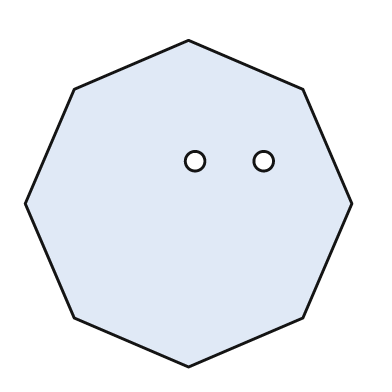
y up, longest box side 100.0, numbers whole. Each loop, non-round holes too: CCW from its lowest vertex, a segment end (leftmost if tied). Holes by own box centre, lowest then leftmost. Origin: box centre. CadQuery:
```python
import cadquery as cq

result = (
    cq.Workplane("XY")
    .moveTo(0.0, -50.0)
    .lineTo(35.0, -35.0)
    .lineTo(50.0, 0.0)
    .lineTo(35.0, 35.0)
    .lineTo(0.0, 50.0)
    .lineTo(-35.0, 35.0)
    .lineTo(-50.0, 0.0)
    .lineTo(-35.0, -35.0)
    .close()
    .moveTo(2.0, 13.0)
    .circle(3.0)
    .moveTo(23.0, 13.0)
    .circle(3.0)
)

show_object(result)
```